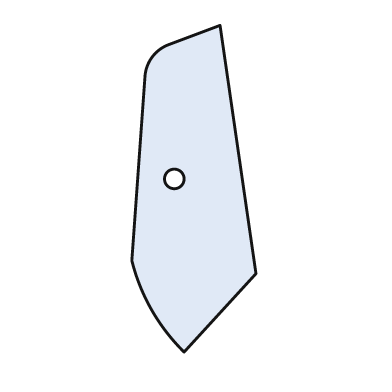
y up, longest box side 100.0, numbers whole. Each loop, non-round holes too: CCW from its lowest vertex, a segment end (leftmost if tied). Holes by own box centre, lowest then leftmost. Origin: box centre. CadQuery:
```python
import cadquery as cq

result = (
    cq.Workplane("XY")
    .moveTo(-3.0, -50.0)
    .lineTo(19.0, -26.0)
    .lineTo(8.0, 50.0)
    .lineTo(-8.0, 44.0)
    .threePointArc((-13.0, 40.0), (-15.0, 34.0))
    .lineTo(-19.0, -22.0)
    .threePointArc((-13.0, -37.0), (-3.0, -50.0))
    .close()
    .moveTo(-6.0, 3.0)
    .circle(3.0)
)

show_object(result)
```